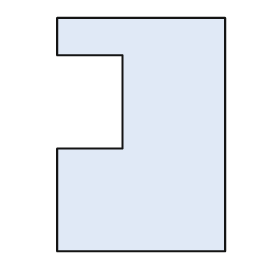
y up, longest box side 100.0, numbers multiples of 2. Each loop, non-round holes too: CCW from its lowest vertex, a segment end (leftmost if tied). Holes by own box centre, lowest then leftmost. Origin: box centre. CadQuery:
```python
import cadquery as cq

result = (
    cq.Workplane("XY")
    .moveTo(-36.0, -50.0)
    .lineTo(36.0, -50.0)
    .lineTo(36.0, 50.0)
    .lineTo(-36.0, 50.0)
    .lineTo(-36.0, 34.0)
    .lineTo(-8.0, 34.0)
    .lineTo(-8.0, -6.0)
    .lineTo(-36.0, -6.0)
    .close()
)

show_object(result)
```